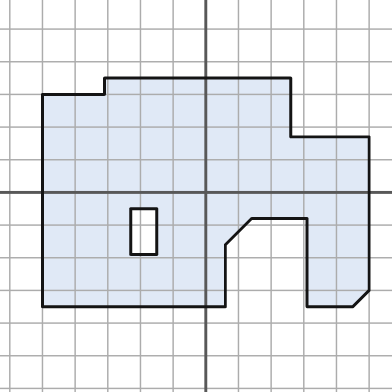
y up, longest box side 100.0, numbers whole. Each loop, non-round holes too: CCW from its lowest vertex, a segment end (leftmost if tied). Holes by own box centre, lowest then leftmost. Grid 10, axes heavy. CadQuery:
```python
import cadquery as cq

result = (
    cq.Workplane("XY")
    .moveTo(-50.0, -35.0)
    .lineTo(6.0, -35.0)
    .lineTo(6.0, -16.0)
    .lineTo(14.0, -8.0)
    .lineTo(31.0, -8.0)
    .lineTo(31.0, -35.0)
    .lineTo(45.0, -35.0)
    .lineTo(50.0, -30.0)
    .lineTo(50.0, 17.0)
    .lineTo(26.0, 17.0)
    .lineTo(26.0, 35.0)
    .lineTo(-31.0, 35.0)
    .lineTo(-31.0, 30.0)
    .lineTo(-50.0, 30.0)
    .close()
    .moveTo(-23.0, -19.0)
    .lineTo(-15.0, -19.0)
    .lineTo(-15.0, -5.0)
    .lineTo(-23.0, -5.0)
    .close()
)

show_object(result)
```